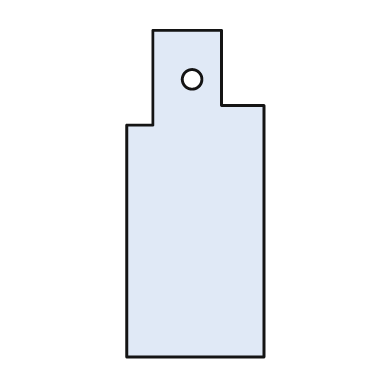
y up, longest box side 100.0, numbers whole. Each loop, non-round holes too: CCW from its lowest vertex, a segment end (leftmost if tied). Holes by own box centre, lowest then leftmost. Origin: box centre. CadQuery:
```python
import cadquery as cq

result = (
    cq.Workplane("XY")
    .moveTo(-21.0, -50.0)
    .lineTo(21.0, -50.0)
    .lineTo(21.0, 27.0)
    .lineTo(8.0, 27.0)
    .lineTo(8.0, 50.0)
    .lineTo(-13.0, 50.0)
    .lineTo(-13.0, 21.0)
    .lineTo(-21.0, 21.0)
    .close()
    .moveTo(-1.0, 35.0)
    .circle(3.0)
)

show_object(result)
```